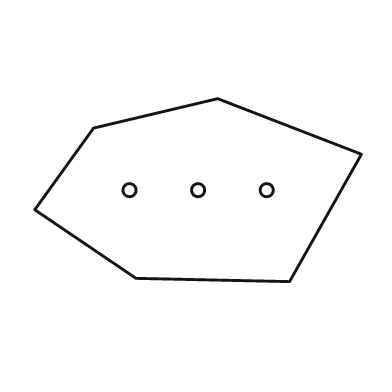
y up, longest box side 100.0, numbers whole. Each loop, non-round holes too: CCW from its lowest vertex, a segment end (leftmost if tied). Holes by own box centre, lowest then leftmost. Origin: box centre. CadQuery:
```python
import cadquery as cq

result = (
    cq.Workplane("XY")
    .moveTo(28.0, -28.0)
    .lineTo(50.0, 11.0)
    .lineTo(6.0, 28.0)
    .lineTo(-32.0, 19.0)
    .lineTo(-50.0, -6.0)
    .lineTo(-19.0, -27.0)
    .close()
    .moveTo(-21.0, 0.0)
    .circle(2.0)
    .moveTo(0.0, 0.0)
    .circle(2.0)
    .moveTo(21.0, 0.0)
    .circle(2.0)
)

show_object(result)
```